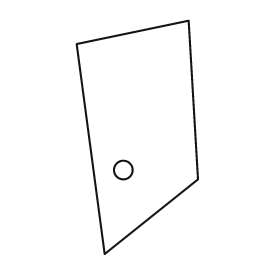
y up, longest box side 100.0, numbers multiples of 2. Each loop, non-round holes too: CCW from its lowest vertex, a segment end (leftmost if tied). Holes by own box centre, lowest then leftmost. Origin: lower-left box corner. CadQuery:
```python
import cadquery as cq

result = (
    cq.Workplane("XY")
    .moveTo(12.0, 0.0)
    .lineTo(52.0, 32.0)
    .lineTo(48.0, 100.0)
    .lineTo(0.0, 90.0)
    .close()
    .moveTo(20.0, 36.0)
    .circle(4.0)
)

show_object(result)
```